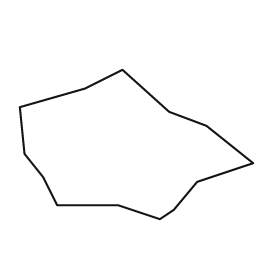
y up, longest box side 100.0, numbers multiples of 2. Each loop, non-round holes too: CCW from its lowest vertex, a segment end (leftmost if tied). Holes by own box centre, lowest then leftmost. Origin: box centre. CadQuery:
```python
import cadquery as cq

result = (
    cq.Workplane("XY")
    .moveTo(10.0, -32.0)
    .lineTo(16.0, -28.0)
    .lineTo(26.0, -16.0)
    .lineTo(50.0, -8.0)
    .lineTo(30.0, 8.0)
    .lineTo(14.0, 14.0)
    .lineTo(-6.0, 32.0)
    .lineTo(-22.0, 24.0)
    .lineTo(-50.0, 16.0)
    .lineTo(-48.0, -4.0)
    .lineTo(-40.0, -14.0)
    .lineTo(-34.0, -26.0)
    .lineTo(-8.0, -26.0)
    .close()
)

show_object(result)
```